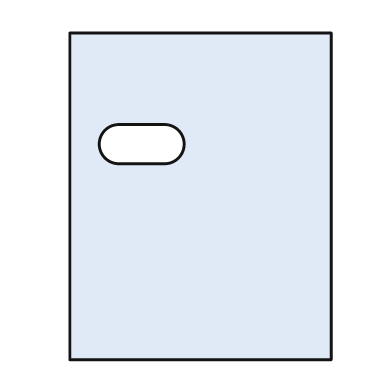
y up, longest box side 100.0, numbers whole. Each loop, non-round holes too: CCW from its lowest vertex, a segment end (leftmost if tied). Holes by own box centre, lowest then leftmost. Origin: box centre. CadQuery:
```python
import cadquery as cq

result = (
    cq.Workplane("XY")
    .moveTo(-40.0, -50.0)
    .lineTo(40.0, -50.0)
    .lineTo(40.0, 50.0)
    .lineTo(-40.0, 50.0)
    .close()
    .moveTo(-25.0, 10.0)
    .lineTo(-11.0, 10.0)
    .threePointArc((-5.0, 16.0), (-11.0, 22.0))
    .lineTo(-25.0, 22.0)
    .threePointArc((-31.0, 16.0), (-25.0, 10.0))
    .close()
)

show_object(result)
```